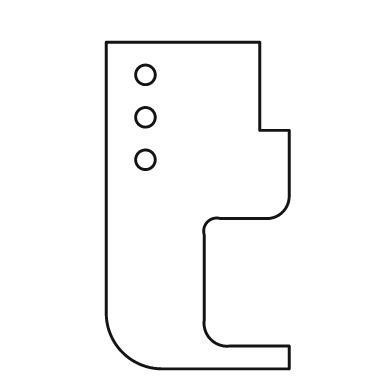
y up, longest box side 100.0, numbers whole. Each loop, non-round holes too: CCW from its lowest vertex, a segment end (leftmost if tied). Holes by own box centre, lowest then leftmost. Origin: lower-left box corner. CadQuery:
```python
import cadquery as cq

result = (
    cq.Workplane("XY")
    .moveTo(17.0, 0.0)
    .lineTo(56.0, 0.0)
    .lineTo(56.0, 7.0)
    .lineTo(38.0, 7.0)
    .threePointArc((32.0, 9.0), (30.0, 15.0))
    .lineTo(30.0, 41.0)
    .threePointArc((31.0, 45.0), (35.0, 46.0))
    .lineTo(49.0, 46.0)
    .threePointArc((54.0, 48.0), (56.0, 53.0))
    .lineTo(56.0, 73.0)
    .lineTo(47.0, 73.0)
    .lineTo(47.0, 100.0)
    .lineTo(0.0, 100.0)
    .lineTo(0.0, 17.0)
    .threePointArc((5.0, 5.0), (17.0, 0.0))
    .close()
    .moveTo(12.0, 64.0)
    .circle(3.0)
    .moveTo(12.0, 77.0)
    .circle(3.0)
    .moveTo(12.0, 90.0)
    .circle(3.0)
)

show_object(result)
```